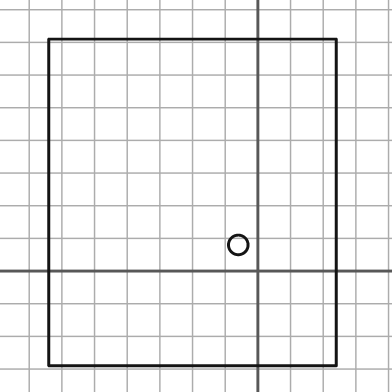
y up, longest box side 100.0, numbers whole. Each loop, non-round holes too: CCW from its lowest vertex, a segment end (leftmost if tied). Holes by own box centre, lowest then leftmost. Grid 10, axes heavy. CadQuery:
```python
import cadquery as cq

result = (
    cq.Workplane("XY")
    .moveTo(-64.0, -29.0)
    .lineTo(24.0, -29.0)
    .lineTo(24.0, 71.0)
    .lineTo(-64.0, 71.0)
    .close()
    .moveTo(-6.0, 8.0)
    .circle(3.0)
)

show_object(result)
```